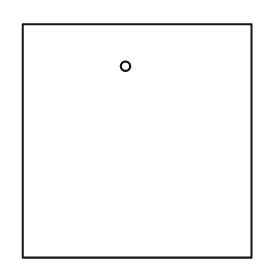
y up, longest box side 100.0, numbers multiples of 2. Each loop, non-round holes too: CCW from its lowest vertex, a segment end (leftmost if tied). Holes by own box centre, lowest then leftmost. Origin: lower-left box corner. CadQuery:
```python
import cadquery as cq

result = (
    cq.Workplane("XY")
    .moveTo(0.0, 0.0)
    .lineTo(98.0, 0.0)
    .lineTo(98.0, 100.0)
    .lineTo(0.0, 100.0)
    .close()
    .moveTo(44.0, 82.0)
    .circle(2.0)
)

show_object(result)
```